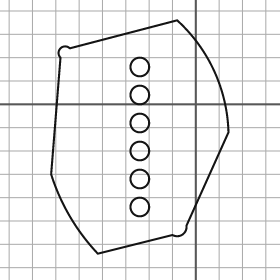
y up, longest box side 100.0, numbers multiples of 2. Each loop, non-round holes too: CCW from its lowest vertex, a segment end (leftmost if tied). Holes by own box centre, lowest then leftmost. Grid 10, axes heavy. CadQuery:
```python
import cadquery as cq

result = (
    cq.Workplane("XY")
    .moveTo(-42.0, -64.0)
    .lineTo(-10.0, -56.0)
    .threePointArc((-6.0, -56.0), (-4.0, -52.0))
    .lineTo(14.0, -12.0)
    .threePointArc((8.0, 14.0), (-8.0, 36.0))
    .lineTo(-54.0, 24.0)
    .threePointArc((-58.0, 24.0), (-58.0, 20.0))
    .lineTo(-62.0, -30.0)
    .threePointArc((-54.0, -48.0), (-42.0, -64.0))
    .close()
    .moveTo(-24.0, -44.0)
    .circle(4.0)
    .moveTo(-24.0, -32.0)
    .circle(4.0)
    .moveTo(-24.0, -20.0)
    .circle(4.0)
    .moveTo(-24.0, -8.0)
    .circle(4.0)
    .moveTo(-24.0, 4.0)
    .circle(4.0)
    .moveTo(-24.0, 16.0)
    .circle(4.0)
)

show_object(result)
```